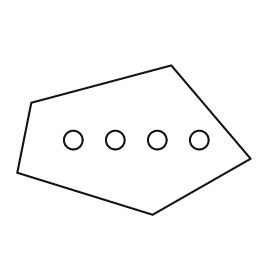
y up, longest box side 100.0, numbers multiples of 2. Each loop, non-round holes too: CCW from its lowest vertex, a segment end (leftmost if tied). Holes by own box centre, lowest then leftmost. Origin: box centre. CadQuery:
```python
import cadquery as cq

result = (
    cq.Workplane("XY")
    .moveTo(8.0, -32.0)
    .lineTo(50.0, -8.0)
    .lineTo(16.0, 32.0)
    .lineTo(-44.0, 16.0)
    .lineTo(-50.0, -14.0)
    .close()
    .moveTo(-26.0, 0.0)
    .circle(4.0)
    .moveTo(-8.0, 0.0)
    .circle(4.0)
    .moveTo(10.0, 0.0)
    .circle(4.0)
    .moveTo(28.0, 0.0)
    .circle(4.0)
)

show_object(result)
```